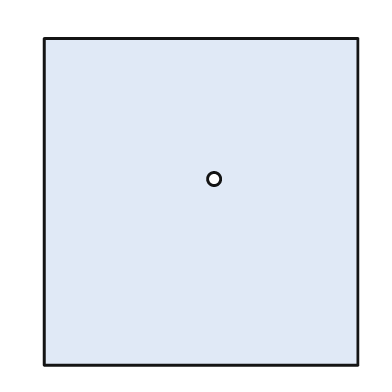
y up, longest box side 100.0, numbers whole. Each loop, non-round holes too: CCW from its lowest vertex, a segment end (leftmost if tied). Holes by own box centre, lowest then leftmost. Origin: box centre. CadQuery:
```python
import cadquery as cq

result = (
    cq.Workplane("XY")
    .moveTo(-48.0, -50.0)
    .lineTo(48.0, -50.0)
    .lineTo(48.0, 50.0)
    .lineTo(-48.0, 50.0)
    .close()
    .moveTo(4.0, 7.0)
    .circle(2.0)
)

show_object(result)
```